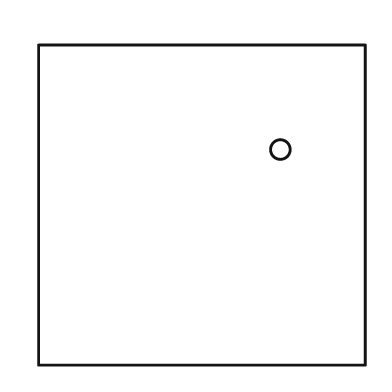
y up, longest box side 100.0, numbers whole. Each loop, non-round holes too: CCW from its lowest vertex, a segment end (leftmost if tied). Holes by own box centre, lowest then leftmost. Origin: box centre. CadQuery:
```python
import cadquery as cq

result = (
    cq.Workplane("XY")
    .moveTo(-50.0, -49.0)
    .lineTo(50.0, -49.0)
    .lineTo(50.0, 49.0)
    .lineTo(-50.0, 49.0)
    .close()
    .moveTo(24.0, 17.0)
    .circle(3.0)
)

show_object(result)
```